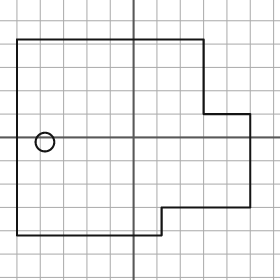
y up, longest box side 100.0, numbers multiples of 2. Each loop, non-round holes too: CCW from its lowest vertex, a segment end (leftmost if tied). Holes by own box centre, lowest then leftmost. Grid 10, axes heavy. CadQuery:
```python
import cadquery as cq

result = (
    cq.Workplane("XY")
    .moveTo(-50.0, -42.0)
    .lineTo(12.0, -42.0)
    .lineTo(12.0, -30.0)
    .lineTo(50.0, -30.0)
    .lineTo(50.0, 10.0)
    .lineTo(30.0, 10.0)
    .lineTo(30.0, 42.0)
    .lineTo(-50.0, 42.0)
    .close()
    .moveTo(-38.0, -2.0)
    .circle(4.0)
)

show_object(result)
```